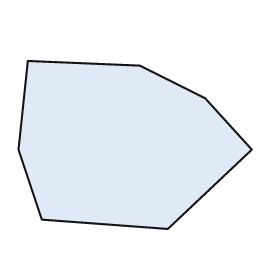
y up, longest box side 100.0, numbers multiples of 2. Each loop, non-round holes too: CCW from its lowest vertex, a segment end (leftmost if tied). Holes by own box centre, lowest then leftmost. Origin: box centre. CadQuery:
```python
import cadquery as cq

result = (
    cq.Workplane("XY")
    .moveTo(14.0, -36.0)
    .lineTo(50.0, -2.0)
    .lineTo(30.0, 20.0)
    .lineTo(2.0, 34.0)
    .lineTo(-46.0, 36.0)
    .lineTo(-50.0, -2.0)
    .lineTo(-40.0, -32.0)
    .close()
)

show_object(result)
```